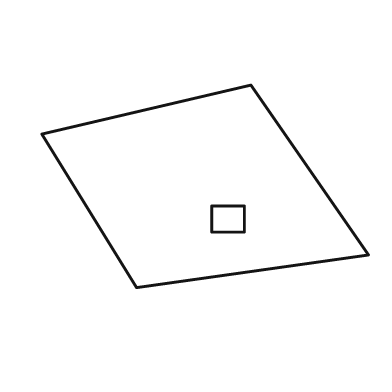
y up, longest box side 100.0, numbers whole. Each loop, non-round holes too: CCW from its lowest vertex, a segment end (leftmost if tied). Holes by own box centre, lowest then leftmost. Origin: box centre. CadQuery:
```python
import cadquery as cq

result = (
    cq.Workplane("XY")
    .moveTo(-21.0, -31.0)
    .lineTo(50.0, -21.0)
    .lineTo(14.0, 31.0)
    .lineTo(-50.0, 16.0)
    .close()
    .moveTo(2.0, -14.0)
    .lineTo(12.0, -14.0)
    .lineTo(12.0, -6.0)
    .lineTo(2.0, -6.0)
    .close()
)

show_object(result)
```